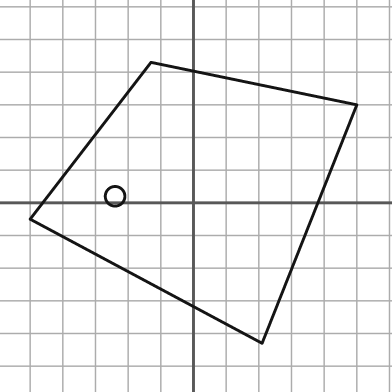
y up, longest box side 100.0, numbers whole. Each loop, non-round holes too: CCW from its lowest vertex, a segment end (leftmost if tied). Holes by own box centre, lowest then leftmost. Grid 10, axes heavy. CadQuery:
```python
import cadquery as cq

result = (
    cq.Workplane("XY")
    .moveTo(21.0, -43.0)
    .lineTo(50.0, 30.0)
    .lineTo(-13.0, 43.0)
    .lineTo(-50.0, -5.0)
    .close()
    .moveTo(-24.0, 2.0)
    .circle(3.0)
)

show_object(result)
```